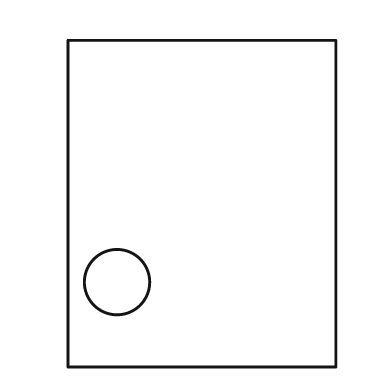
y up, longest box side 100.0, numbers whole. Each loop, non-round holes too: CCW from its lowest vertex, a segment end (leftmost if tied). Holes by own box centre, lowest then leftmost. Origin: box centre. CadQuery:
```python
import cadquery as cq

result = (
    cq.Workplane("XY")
    .moveTo(-41.0, -50.0)
    .lineTo(41.0, -50.0)
    .lineTo(41.0, 50.0)
    .lineTo(-41.0, 50.0)
    .close()
    .moveTo(-26.0, -24.0)
    .circle(10.0)
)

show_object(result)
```